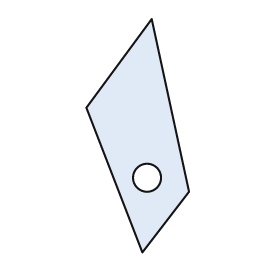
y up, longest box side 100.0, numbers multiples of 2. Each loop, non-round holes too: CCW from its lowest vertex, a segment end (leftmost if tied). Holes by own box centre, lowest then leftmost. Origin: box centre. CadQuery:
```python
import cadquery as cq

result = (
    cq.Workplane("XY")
    .moveTo(2.0, -50.0)
    .lineTo(22.0, -24.0)
    .lineTo(6.0, 50.0)
    .lineTo(-22.0, 12.0)
    .close()
    .moveTo(4.0, -18.0)
    .circle(6.0)
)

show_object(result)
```